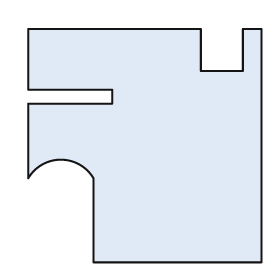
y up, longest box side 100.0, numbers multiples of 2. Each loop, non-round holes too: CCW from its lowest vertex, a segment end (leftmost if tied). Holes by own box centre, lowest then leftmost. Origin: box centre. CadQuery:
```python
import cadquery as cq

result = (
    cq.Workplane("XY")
    .moveTo(-22.0, -50.0)
    .lineTo(50.0, -50.0)
    .lineTo(50.0, 50.0)
    .lineTo(42.0, 50.0)
    .lineTo(42.0, 32.0)
    .lineTo(24.0, 32.0)
    .lineTo(24.0, 50.0)
    .lineTo(-50.0, 50.0)
    .lineTo(-50.0, 24.0)
    .lineTo(-14.0, 24.0)
    .lineTo(-14.0, 18.0)
    .lineTo(-50.0, 18.0)
    .lineTo(-50.0, -14.0)
    .threePointArc((-36.0, -6.0), (-22.0, -14.0))
    .close()
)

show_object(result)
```